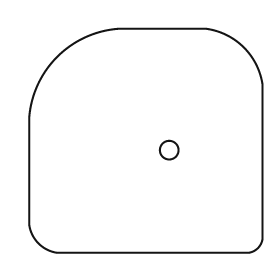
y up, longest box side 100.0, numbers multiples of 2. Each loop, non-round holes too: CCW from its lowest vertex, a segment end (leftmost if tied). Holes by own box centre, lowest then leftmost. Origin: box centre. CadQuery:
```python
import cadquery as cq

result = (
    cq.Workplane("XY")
    .moveTo(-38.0, -48.0)
    .lineTo(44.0, -48.0)
    .threePointArc((48.0, -46.0), (50.0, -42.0))
    .lineTo(50.0, 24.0)
    .threePointArc((42.0, 40.0), (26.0, 48.0))
    .lineTo(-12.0, 48.0)
    .threePointArc((-38.0, 36.0), (-50.0, 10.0))
    .lineTo(-50.0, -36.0)
    .threePointArc((-46.0, -44.0), (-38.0, -48.0))
    .close()
    .moveTo(10.0, -4.0)
    .circle(4.0)
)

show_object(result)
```